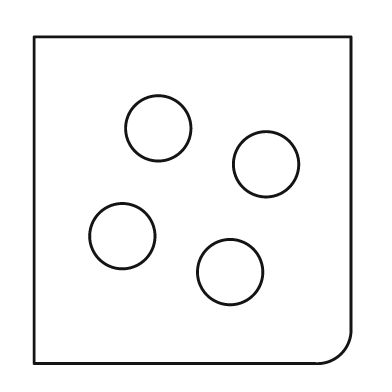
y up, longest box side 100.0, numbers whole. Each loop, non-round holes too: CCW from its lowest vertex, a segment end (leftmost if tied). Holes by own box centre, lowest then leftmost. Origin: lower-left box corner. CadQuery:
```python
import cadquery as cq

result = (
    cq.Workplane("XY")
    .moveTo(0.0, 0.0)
    .lineTo(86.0, 0.0)
    .threePointArc((94.0, 3.0), (97.0, 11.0))
    .lineTo(97.0, 100.0)
    .lineTo(0.0, 100.0)
    .close()
    .moveTo(60.0, 28.0)
    .circle(10.0)
    .moveTo(27.0, 39.0)
    .circle(10.0)
    .moveTo(71.0, 61.0)
    .circle(10.0)
    .moveTo(38.0, 72.0)
    .circle(10.0)
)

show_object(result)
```